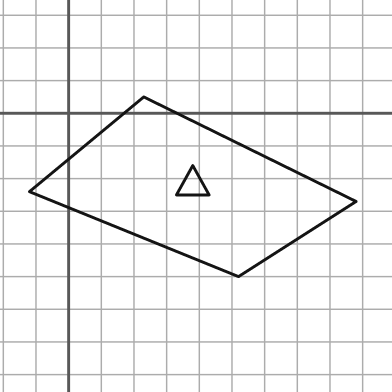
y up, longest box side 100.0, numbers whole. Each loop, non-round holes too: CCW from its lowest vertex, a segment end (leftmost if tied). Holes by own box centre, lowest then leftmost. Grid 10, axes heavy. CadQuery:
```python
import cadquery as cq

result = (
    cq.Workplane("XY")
    .moveTo(52.0, -50.0)
    .lineTo(88.0, -27.0)
    .lineTo(23.0, 5.0)
    .lineTo(-12.0, -24.0)
    .close()
    .moveTo(33.0, -25.0)
    .lineTo(43.0, -25.0)
    .lineTo(38.0, -16.0)
    .close()
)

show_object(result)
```